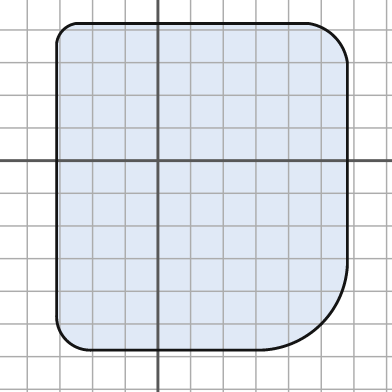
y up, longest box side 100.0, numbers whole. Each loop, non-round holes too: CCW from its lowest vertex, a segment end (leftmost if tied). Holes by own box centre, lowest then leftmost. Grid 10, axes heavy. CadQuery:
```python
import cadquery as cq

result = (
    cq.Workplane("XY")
    .moveTo(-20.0, -58.0)
    .lineTo(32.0, -58.0)
    .threePointArc((50.0, -50.0), (58.0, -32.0))
    .lineTo(58.0, 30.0)
    .threePointArc((54.0, 38.0), (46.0, 42.0))
    .lineTo(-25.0, 42.0)
    .threePointArc((-29.0, 40.0), (-31.0, 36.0))
    .lineTo(-31.0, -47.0)
    .threePointArc((-28.0, -55.0), (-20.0, -58.0))
    .close()
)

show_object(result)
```